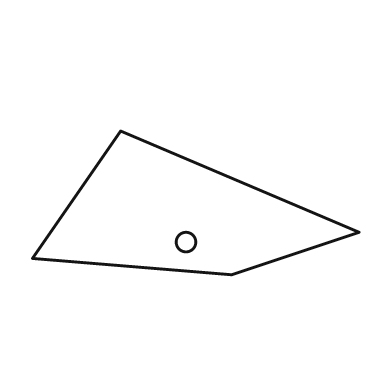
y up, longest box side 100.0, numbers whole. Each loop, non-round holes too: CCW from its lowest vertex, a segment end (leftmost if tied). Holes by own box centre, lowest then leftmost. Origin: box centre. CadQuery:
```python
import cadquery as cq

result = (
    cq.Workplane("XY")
    .moveTo(11.0, -22.0)
    .lineTo(50.0, -9.0)
    .lineTo(-23.0, 22.0)
    .lineTo(-50.0, -17.0)
    .close()
    .moveTo(-3.0, -12.0)
    .circle(3.0)
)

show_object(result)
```